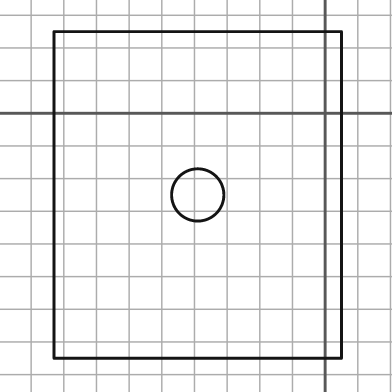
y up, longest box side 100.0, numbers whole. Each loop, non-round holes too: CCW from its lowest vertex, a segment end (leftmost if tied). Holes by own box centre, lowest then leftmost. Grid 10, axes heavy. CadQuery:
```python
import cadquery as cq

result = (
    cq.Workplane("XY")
    .moveTo(-83.0, -75.0)
    .lineTo(5.0, -75.0)
    .lineTo(5.0, 25.0)
    .lineTo(-83.0, 25.0)
    .close()
    .moveTo(-39.0, -25.0)
    .circle(8.0)
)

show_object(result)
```